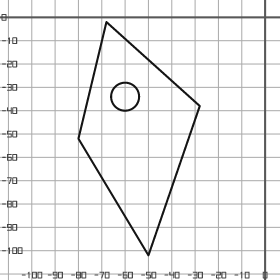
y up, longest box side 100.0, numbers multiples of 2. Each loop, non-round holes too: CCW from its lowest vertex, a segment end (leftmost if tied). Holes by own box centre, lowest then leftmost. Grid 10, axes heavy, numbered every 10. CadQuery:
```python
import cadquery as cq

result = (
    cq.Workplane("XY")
    .moveTo(-50.0, -102.0)
    .lineTo(-28.0, -38.0)
    .lineTo(-68.0, -2.0)
    .lineTo(-80.0, -52.0)
    .close()
    .moveTo(-60.0, -34.0)
    .circle(6.0)
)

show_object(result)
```